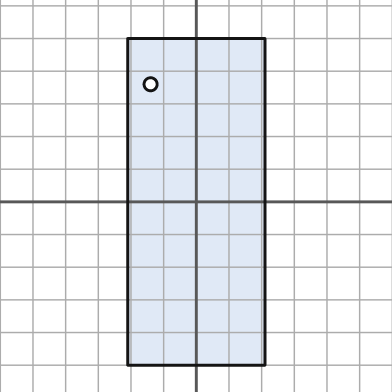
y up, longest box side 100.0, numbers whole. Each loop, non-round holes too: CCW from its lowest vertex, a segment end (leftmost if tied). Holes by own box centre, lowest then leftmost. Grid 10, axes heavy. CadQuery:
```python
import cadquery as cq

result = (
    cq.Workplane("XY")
    .moveTo(-21.0, -50.0)
    .lineTo(21.0, -50.0)
    .lineTo(21.0, 50.0)
    .lineTo(-21.0, 50.0)
    .close()
    .moveTo(-14.0, 36.0)
    .circle(2.0)
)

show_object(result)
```